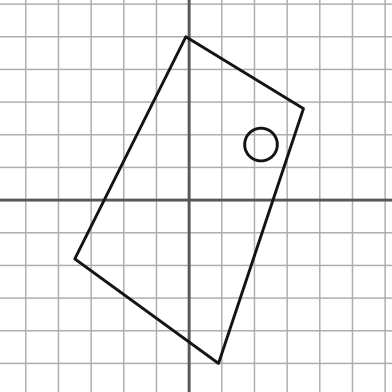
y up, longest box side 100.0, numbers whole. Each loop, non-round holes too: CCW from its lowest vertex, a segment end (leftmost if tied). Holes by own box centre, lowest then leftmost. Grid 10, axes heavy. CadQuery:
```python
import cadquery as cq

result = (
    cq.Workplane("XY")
    .moveTo(9.0, -50.0)
    .lineTo(35.0, 28.0)
    .lineTo(-1.0, 50.0)
    .lineTo(-35.0, -18.0)
    .close()
    .moveTo(22.0, 17.0)
    .circle(5.0)
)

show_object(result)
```